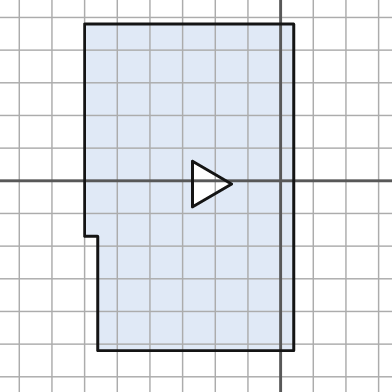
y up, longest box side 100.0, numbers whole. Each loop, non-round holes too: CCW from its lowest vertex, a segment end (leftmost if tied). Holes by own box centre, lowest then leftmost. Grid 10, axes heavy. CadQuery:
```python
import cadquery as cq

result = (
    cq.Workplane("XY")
    .moveTo(-56.0, -52.0)
    .lineTo(4.0, -52.0)
    .lineTo(4.0, 48.0)
    .lineTo(-60.0, 48.0)
    .lineTo(-60.0, -17.0)
    .lineTo(-56.0, -17.0)
    .close()
    .moveTo(-27.0, -8.0)
    .lineTo(-15.0, -1.0)
    .lineTo(-27.0, 6.0)
    .close()
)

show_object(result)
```